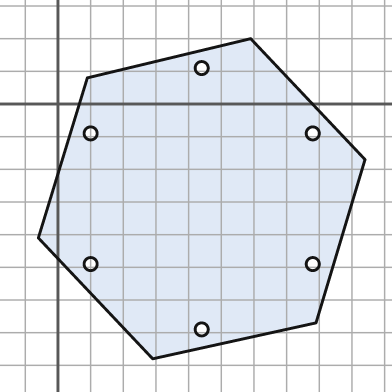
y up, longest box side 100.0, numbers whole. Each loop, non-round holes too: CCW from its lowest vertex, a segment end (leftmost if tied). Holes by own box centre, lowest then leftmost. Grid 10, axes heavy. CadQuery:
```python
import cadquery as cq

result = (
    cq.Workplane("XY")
    .moveTo(29.0, -78.0)
    .lineTo(79.0, -67.0)
    .lineTo(94.0, -17.0)
    .lineTo(59.0, 20.0)
    .lineTo(9.0, 8.0)
    .lineTo(-6.0, -41.0)
    .close()
    .moveTo(44.0, -69.0)
    .circle(2.0)
    .moveTo(10.0, -49.0)
    .circle(2.0)
    .moveTo(78.0, -49.0)
    .circle(2.0)
    .moveTo(10.0, -9.0)
    .circle(2.0)
    .moveTo(78.0, -9.0)
    .circle(2.0)
    .moveTo(44.0, 11.0)
    .circle(2.0)
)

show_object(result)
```